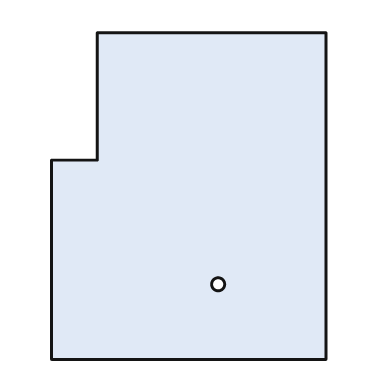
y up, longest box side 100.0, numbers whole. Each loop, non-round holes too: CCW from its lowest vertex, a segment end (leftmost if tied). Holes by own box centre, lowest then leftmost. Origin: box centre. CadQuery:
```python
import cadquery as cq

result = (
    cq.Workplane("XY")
    .moveTo(-42.0, -50.0)
    .lineTo(42.0, -50.0)
    .lineTo(42.0, 50.0)
    .lineTo(-28.0, 50.0)
    .lineTo(-28.0, 11.0)
    .lineTo(-42.0, 11.0)
    .close()
    .moveTo(9.0, -27.0)
    .circle(2.0)
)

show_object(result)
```